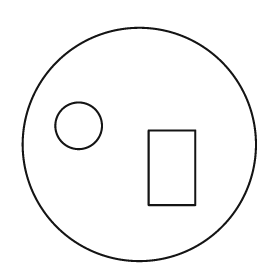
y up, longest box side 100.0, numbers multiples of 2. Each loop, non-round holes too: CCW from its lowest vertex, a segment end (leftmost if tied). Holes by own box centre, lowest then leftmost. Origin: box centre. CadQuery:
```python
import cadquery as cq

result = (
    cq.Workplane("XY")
    .moveTo(0.0, 0.0)
    .circle(50.0)
    .moveTo(4.0, -26.0)
    .lineTo(24.0, -26.0)
    .lineTo(24.0, 6.0)
    .lineTo(4.0, 6.0)
    .close()
    .moveTo(-26.0, 8.0)
    .circle(10.0)
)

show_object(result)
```